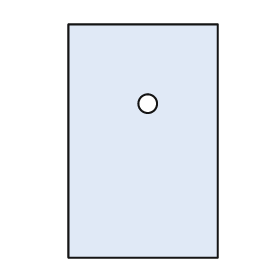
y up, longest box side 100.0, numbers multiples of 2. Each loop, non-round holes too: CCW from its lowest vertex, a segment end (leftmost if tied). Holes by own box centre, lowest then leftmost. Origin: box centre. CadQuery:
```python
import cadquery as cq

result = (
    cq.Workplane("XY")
    .moveTo(-32.0, -50.0)
    .lineTo(32.0, -50.0)
    .lineTo(32.0, 50.0)
    .lineTo(-32.0, 50.0)
    .close()
    .moveTo(2.0, 16.0)
    .circle(4.0)
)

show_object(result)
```